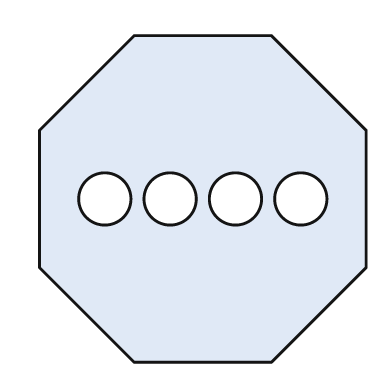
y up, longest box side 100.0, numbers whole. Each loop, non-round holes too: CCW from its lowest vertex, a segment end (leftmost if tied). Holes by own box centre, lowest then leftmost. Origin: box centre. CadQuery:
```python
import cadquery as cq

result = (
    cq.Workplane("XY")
    .moveTo(-21.0, -50.0)
    .lineTo(21.0, -50.0)
    .lineTo(50.0, -21.0)
    .lineTo(50.0, 21.0)
    .lineTo(21.0, 50.0)
    .lineTo(-21.0, 50.0)
    .lineTo(-50.0, 21.0)
    .lineTo(-50.0, -21.0)
    .close()
    .moveTo(-30.0, 0.0)
    .circle(8.0)
    .moveTo(-10.0, 0.0)
    .circle(8.0)
    .moveTo(10.0, 0.0)
    .circle(8.0)
    .moveTo(30.0, 0.0)
    .circle(8.0)
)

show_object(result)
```